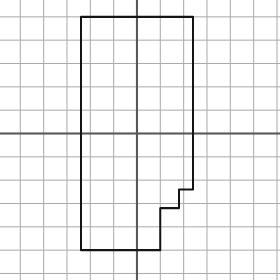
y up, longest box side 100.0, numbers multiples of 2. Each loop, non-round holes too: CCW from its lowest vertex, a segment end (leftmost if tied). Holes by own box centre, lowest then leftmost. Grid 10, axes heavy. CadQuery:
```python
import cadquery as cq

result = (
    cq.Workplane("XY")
    .moveTo(-24.0, -50.0)
    .lineTo(10.0, -50.0)
    .lineTo(10.0, -32.0)
    .lineTo(18.0, -32.0)
    .lineTo(18.0, -24.0)
    .lineTo(24.0, -24.0)
    .lineTo(24.0, 50.0)
    .lineTo(-24.0, 50.0)
    .close()
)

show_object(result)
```